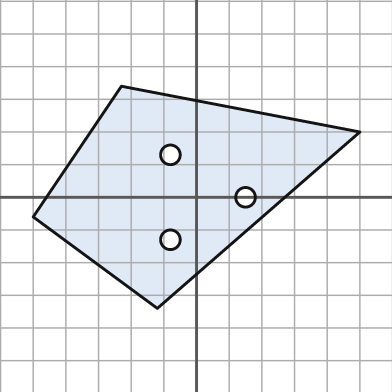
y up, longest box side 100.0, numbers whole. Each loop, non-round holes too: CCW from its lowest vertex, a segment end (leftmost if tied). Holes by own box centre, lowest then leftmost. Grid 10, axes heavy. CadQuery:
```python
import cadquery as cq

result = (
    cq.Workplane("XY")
    .moveTo(-12.0, -34.0)
    .lineTo(50.0, 20.0)
    .lineTo(-23.0, 34.0)
    .lineTo(-50.0, -6.0)
    .close()
    .moveTo(-8.0, -13.0)
    .circle(3.0)
    .moveTo(15.0, 0.0)
    .circle(3.0)
    .moveTo(-8.0, 13.0)
    .circle(3.0)
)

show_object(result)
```